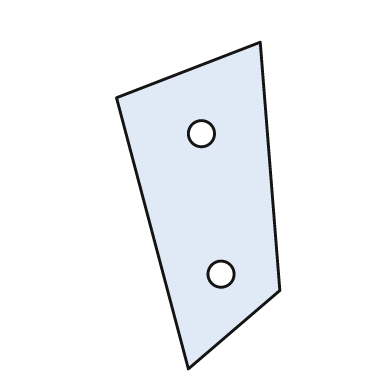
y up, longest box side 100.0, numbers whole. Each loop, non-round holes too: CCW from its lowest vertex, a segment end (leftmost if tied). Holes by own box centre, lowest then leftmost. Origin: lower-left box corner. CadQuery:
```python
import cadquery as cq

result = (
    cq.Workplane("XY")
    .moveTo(22.0, 0.0)
    .lineTo(50.0, 24.0)
    .lineTo(44.0, 100.0)
    .lineTo(0.0, 83.0)
    .close()
    .moveTo(32.0, 29.0)
    .circle(4.0)
    .moveTo(26.0, 72.0)
    .circle(4.0)
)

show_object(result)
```